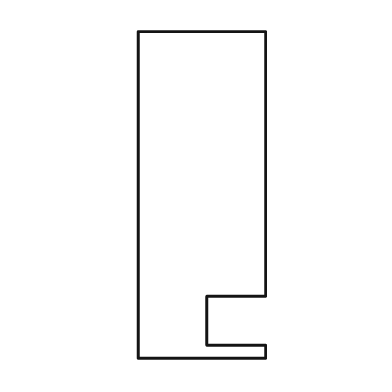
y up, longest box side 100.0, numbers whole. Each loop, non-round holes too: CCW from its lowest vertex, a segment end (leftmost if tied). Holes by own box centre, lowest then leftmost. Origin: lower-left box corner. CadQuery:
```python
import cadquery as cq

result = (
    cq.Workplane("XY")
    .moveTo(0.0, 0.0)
    .lineTo(39.0, 0.0)
    .lineTo(39.0, 4.0)
    .lineTo(21.0, 4.0)
    .lineTo(21.0, 19.0)
    .lineTo(39.0, 19.0)
    .lineTo(39.0, 100.0)
    .lineTo(0.0, 100.0)
    .close()
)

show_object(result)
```